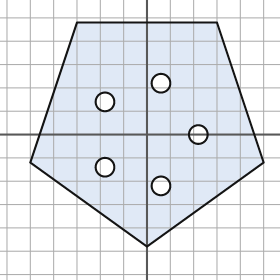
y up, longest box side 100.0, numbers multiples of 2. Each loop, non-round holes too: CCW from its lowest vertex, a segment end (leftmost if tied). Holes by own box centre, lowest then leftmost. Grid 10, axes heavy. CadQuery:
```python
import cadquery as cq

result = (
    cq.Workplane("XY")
    .moveTo(0.0, -48.0)
    .lineTo(50.0, -12.0)
    .lineTo(30.0, 48.0)
    .lineTo(-30.0, 48.0)
    .lineTo(-50.0, -12.0)
    .close()
    .moveTo(6.0, -22.0)
    .circle(4.0)
    .moveTo(-18.0, -14.0)
    .circle(4.0)
    .moveTo(22.0, 0.0)
    .circle(4.0)
    .moveTo(-18.0, 14.0)
    .circle(4.0)
    .moveTo(6.0, 22.0)
    .circle(4.0)
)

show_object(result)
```